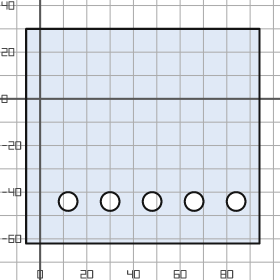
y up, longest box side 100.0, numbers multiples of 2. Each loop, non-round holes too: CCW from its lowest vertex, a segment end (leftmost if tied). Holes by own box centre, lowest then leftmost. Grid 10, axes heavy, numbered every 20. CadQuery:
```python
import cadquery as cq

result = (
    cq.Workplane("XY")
    .moveTo(-6.0, -62.0)
    .lineTo(94.0, -62.0)
    .lineTo(94.0, 30.0)
    .lineTo(-6.0, 30.0)
    .close()
    .moveTo(12.0, -44.0)
    .circle(4.0)
    .moveTo(30.0, -44.0)
    .circle(4.0)
    .moveTo(48.0, -44.0)
    .circle(4.0)
    .moveTo(66.0, -44.0)
    .circle(4.0)
    .moveTo(84.0, -44.0)
    .circle(4.0)
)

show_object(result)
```